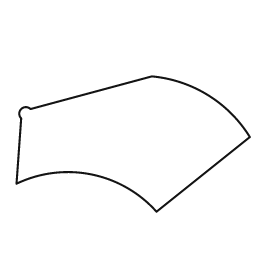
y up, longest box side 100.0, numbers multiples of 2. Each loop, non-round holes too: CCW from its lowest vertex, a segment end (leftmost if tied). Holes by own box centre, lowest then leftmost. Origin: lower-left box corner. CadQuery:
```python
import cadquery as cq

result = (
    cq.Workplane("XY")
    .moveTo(60.0, 0.0)
    .lineTo(100.0, 32.0)
    .threePointArc((82.0, 50.0), (58.0, 58.0))
    .lineTo(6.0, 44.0)
    .threePointArc((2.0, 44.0), (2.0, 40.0))
    .lineTo(0.0, 12.0)
    .threePointArc((32.0, 16.0), (60.0, 0.0))
    .close()
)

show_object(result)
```